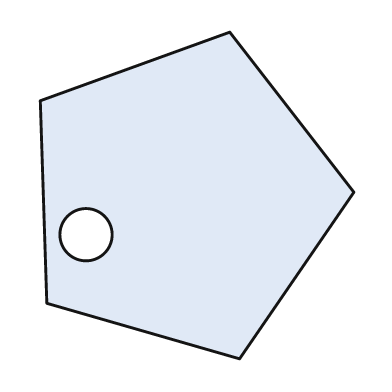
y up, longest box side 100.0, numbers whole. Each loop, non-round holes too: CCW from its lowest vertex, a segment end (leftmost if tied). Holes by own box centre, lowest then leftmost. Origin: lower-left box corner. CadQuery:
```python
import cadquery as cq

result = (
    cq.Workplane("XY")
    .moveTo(61.0, 0.0)
    .lineTo(96.0, 51.0)
    .lineTo(58.0, 100.0)
    .lineTo(0.0, 79.0)
    .lineTo(2.0, 17.0)
    .close()
    .moveTo(14.0, 38.0)
    .circle(8.0)
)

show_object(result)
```